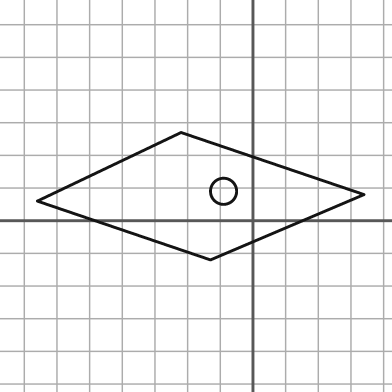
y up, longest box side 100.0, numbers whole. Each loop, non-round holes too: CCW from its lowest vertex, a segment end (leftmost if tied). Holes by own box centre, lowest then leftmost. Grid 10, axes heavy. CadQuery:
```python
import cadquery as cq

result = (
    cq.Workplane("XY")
    .moveTo(-13.0, -12.0)
    .lineTo(34.0, 8.0)
    .lineTo(-22.0, 27.0)
    .lineTo(-66.0, 6.0)
    .close()
    .moveTo(-9.0, 9.0)
    .circle(4.0)
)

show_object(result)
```